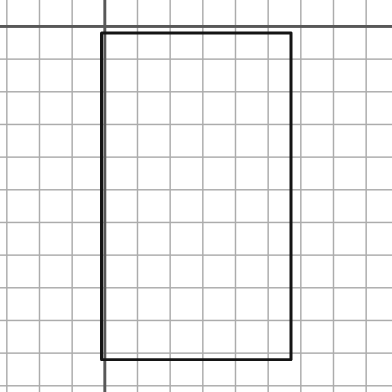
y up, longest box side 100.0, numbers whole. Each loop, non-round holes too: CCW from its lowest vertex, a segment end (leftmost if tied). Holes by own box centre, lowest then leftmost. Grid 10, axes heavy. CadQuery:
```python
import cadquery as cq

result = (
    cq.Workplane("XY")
    .moveTo(-1.0, -102.0)
    .lineTo(57.0, -102.0)
    .lineTo(57.0, -2.0)
    .lineTo(-1.0, -2.0)
    .close()
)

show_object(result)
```